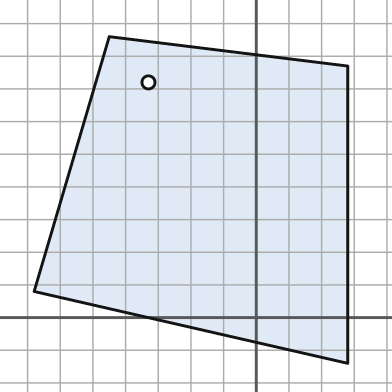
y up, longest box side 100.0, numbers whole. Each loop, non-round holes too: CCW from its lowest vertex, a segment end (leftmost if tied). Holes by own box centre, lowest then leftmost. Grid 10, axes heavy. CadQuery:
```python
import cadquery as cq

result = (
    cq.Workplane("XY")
    .moveTo(28.0, -14.0)
    .lineTo(28.0, 77.0)
    .lineTo(-45.0, 86.0)
    .lineTo(-68.0, 8.0)
    .close()
    .moveTo(-33.0, 72.0)
    .circle(2.0)
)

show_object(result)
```